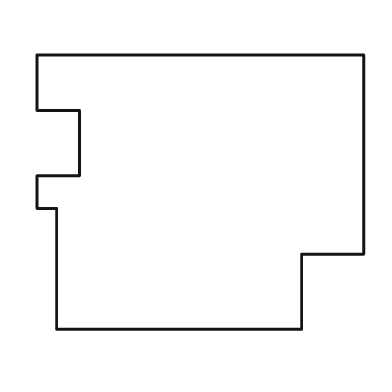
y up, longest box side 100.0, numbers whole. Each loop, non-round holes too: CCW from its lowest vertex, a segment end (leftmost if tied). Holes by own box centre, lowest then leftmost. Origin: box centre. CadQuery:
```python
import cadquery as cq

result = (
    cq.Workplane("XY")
    .moveTo(-44.0, -42.0)
    .lineTo(31.0, -42.0)
    .lineTo(31.0, -19.0)
    .lineTo(50.0, -19.0)
    .lineTo(50.0, 42.0)
    .lineTo(-50.0, 42.0)
    .lineTo(-50.0, 25.0)
    .lineTo(-37.0, 25.0)
    .lineTo(-37.0, 5.0)
    .lineTo(-50.0, 5.0)
    .lineTo(-50.0, -5.0)
    .lineTo(-44.0, -5.0)
    .close()
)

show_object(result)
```